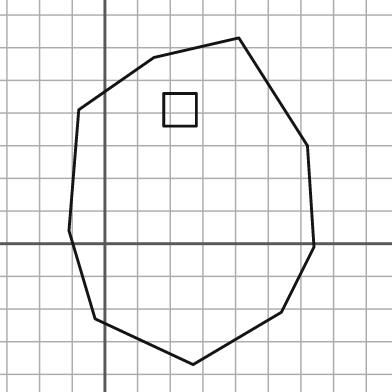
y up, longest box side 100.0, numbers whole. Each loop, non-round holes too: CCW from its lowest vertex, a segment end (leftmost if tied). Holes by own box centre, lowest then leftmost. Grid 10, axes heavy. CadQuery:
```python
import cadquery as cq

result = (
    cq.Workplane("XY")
    .moveTo(27.0, -37.0)
    .lineTo(54.0, -21.0)
    .lineTo(64.0, -1.0)
    .lineTo(62.0, 30.0)
    .lineTo(41.0, 63.0)
    .lineTo(15.0, 57.0)
    .lineTo(-8.0, 41.0)
    .lineTo(-11.0, 4.0)
    .lineTo(-3.0, -23.0)
    .close()
    .moveTo(18.0, 36.0)
    .lineTo(28.0, 36.0)
    .lineTo(28.0, 46.0)
    .lineTo(18.0, 46.0)
    .close()
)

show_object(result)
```